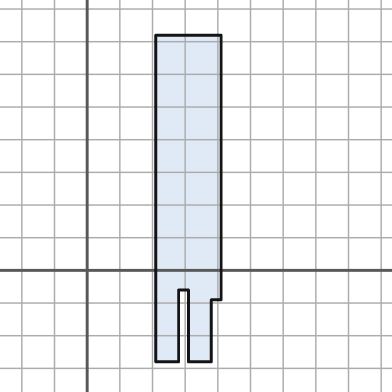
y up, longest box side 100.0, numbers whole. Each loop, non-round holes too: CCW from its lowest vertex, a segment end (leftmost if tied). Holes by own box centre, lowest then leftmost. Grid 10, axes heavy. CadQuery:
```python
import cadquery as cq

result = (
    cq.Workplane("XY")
    .moveTo(21.0, -28.0)
    .lineTo(28.0, -28.0)
    .lineTo(28.0, -6.0)
    .lineTo(31.0, -6.0)
    .lineTo(31.0, -28.0)
    .lineTo(38.0, -28.0)
    .lineTo(38.0, -9.0)
    .lineTo(41.0, -9.0)
    .lineTo(41.0, 72.0)
    .lineTo(21.0, 72.0)
    .close()
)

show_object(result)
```